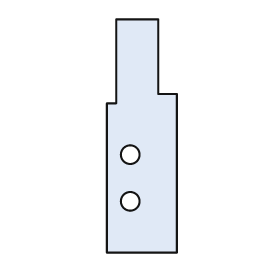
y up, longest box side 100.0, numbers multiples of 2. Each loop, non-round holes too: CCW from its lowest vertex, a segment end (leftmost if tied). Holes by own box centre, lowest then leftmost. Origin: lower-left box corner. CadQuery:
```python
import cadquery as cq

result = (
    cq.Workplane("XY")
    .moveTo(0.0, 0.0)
    .lineTo(30.0, 0.0)
    .lineTo(30.0, 68.0)
    .lineTo(22.0, 68.0)
    .lineTo(22.0, 100.0)
    .lineTo(4.0, 100.0)
    .lineTo(4.0, 64.0)
    .lineTo(0.0, 64.0)
    .close()
    .moveTo(10.0, 22.0)
    .circle(4.0)
    .moveTo(10.0, 42.0)
    .circle(4.0)
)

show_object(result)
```